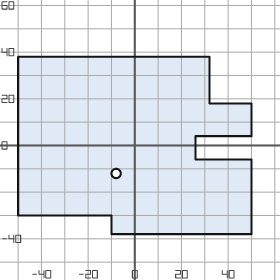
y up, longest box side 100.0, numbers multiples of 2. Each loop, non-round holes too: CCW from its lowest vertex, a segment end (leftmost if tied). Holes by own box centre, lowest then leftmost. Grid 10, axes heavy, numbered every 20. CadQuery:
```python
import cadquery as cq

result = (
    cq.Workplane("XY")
    .moveTo(-10.0, -38.0)
    .lineTo(50.0, -38.0)
    .lineTo(50.0, -6.0)
    .lineTo(26.0, -6.0)
    .lineTo(26.0, 4.0)
    .lineTo(50.0, 4.0)
    .lineTo(50.0, 18.0)
    .lineTo(32.0, 18.0)
    .lineTo(32.0, 38.0)
    .lineTo(-50.0, 38.0)
    .lineTo(-50.0, -30.0)
    .lineTo(-10.0, -30.0)
    .close()
    .moveTo(-8.0, -12.0)
    .circle(2.0)
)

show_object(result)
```